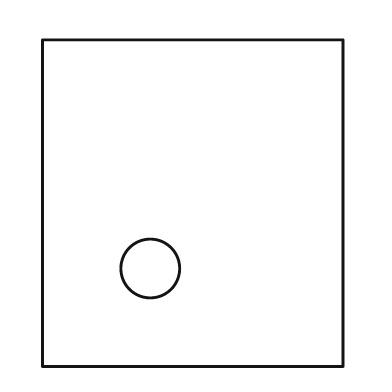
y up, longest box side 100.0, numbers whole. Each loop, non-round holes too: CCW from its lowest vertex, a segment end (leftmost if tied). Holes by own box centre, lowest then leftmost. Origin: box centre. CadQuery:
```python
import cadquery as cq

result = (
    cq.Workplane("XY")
    .moveTo(-46.0, -50.0)
    .lineTo(46.0, -50.0)
    .lineTo(46.0, 50.0)
    .lineTo(-46.0, 50.0)
    .close()
    .moveTo(-13.0, -20.0)
    .circle(9.0)
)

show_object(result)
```